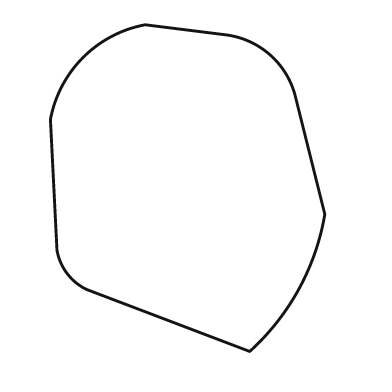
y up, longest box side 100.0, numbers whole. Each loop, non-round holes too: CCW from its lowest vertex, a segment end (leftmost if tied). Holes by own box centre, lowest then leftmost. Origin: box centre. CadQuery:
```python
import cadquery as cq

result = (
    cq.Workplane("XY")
    .moveTo(19.0, -50.0)
    .threePointArc((34.0, -31.0), (42.0, -8.0))
    .lineTo(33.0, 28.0)
    .threePointArc((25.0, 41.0), (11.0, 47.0))
    .lineTo(-13.0, 50.0)
    .threePointArc((-32.0, 40.0), (-42.0, 21.0))
    .lineTo(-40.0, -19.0)
    .threePointArc((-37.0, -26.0), (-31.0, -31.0))
    .close()
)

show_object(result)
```